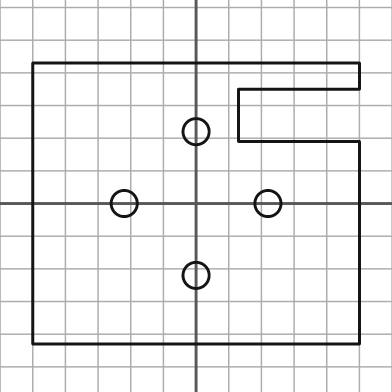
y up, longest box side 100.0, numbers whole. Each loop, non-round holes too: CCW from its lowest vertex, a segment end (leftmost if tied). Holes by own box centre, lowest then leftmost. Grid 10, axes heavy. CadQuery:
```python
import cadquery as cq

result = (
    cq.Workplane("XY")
    .moveTo(-50.0, -43.0)
    .lineTo(50.0, -43.0)
    .lineTo(50.0, 19.0)
    .lineTo(13.0, 19.0)
    .lineTo(13.0, 35.0)
    .lineTo(50.0, 35.0)
    .lineTo(50.0, 43.0)
    .lineTo(-50.0, 43.0)
    .close()
    .moveTo(0.0, -22.0)
    .circle(4.0)
    .moveTo(-22.0, 0.0)
    .circle(4.0)
    .moveTo(22.0, 0.0)
    .circle(4.0)
    .moveTo(0.0, 22.0)
    .circle(4.0)
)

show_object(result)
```